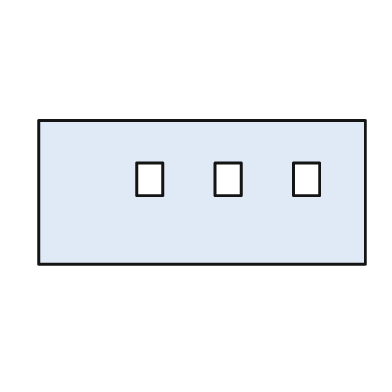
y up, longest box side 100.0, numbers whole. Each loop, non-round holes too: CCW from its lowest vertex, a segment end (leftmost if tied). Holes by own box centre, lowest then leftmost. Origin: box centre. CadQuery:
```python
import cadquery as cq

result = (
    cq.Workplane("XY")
    .moveTo(-50.0, -22.0)
    .lineTo(50.0, -22.0)
    .lineTo(50.0, 22.0)
    .lineTo(-50.0, 22.0)
    .close()
    .moveTo(-20.0, -1.0)
    .lineTo(-12.0, -1.0)
    .lineTo(-12.0, 9.0)
    .lineTo(-20.0, 9.0)
    .close()
    .moveTo(4.0, -1.0)
    .lineTo(12.0, -1.0)
    .lineTo(12.0, 9.0)
    .lineTo(4.0, 9.0)
    .close()
    .moveTo(28.0, -1.0)
    .lineTo(36.0, -1.0)
    .lineTo(36.0, 9.0)
    .lineTo(28.0, 9.0)
    .close()
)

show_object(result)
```